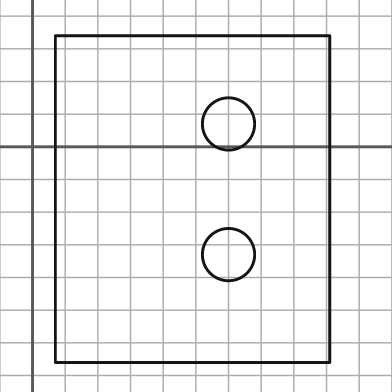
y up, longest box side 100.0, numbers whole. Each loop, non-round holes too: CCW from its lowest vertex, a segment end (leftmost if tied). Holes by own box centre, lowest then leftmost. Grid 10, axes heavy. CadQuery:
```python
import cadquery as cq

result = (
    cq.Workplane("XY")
    .moveTo(7.0, -66.0)
    .lineTo(91.0, -66.0)
    .lineTo(91.0, 34.0)
    .lineTo(7.0, 34.0)
    .close()
    .moveTo(60.0, -33.0)
    .circle(8.0)
    .moveTo(60.0, 7.0)
    .circle(8.0)
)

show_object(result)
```